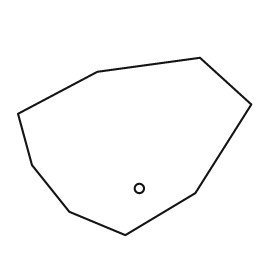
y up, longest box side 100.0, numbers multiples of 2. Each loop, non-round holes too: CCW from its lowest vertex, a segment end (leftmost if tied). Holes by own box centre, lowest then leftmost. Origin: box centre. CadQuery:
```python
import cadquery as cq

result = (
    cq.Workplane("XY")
    .moveTo(-4.0, -38.0)
    .lineTo(26.0, -20.0)
    .lineTo(50.0, 18.0)
    .lineTo(28.0, 38.0)
    .lineTo(-16.0, 32.0)
    .lineTo(-50.0, 14.0)
    .lineTo(-44.0, -8.0)
    .lineTo(-28.0, -28.0)
    .close()
    .moveTo(2.0, -18.0)
    .circle(2.0)
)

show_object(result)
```